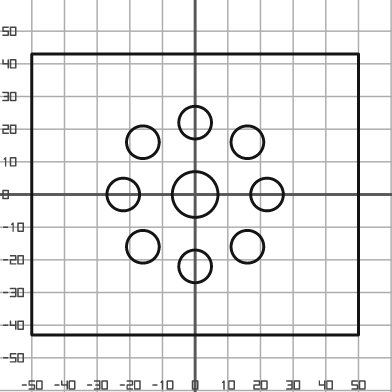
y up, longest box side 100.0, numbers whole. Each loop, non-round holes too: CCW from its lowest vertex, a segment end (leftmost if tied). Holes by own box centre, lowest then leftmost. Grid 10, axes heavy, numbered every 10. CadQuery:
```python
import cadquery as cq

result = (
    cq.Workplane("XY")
    .moveTo(-50.0, -43.0)
    .lineTo(50.0, -43.0)
    .lineTo(50.0, 43.0)
    .lineTo(-50.0, 43.0)
    .close()
    .moveTo(0.0, -22.0)
    .circle(5.0)
    .moveTo(-16.0, -16.0)
    .circle(5.0)
    .moveTo(16.0, -16.0)
    .circle(5.0)
    .moveTo(-22.0, 0.0)
    .circle(5.0)
    .moveTo(0.0, 0.0)
    .circle(7.0)
    .moveTo(22.0, 0.0)
    .circle(5.0)
    .moveTo(-16.0, 16.0)
    .circle(5.0)
    .moveTo(16.0, 16.0)
    .circle(5.0)
    .moveTo(0.0, 22.0)
    .circle(5.0)
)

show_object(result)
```